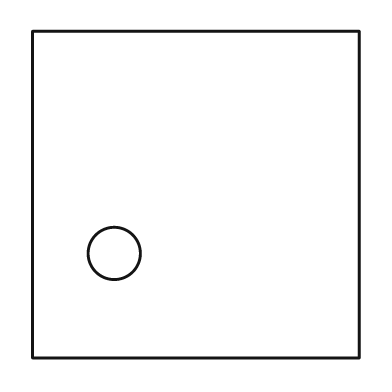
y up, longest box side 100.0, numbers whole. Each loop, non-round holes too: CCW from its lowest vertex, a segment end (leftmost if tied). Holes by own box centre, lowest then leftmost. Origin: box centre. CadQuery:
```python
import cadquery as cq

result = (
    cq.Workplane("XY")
    .moveTo(-50.0, -50.0)
    .lineTo(50.0, -50.0)
    .lineTo(50.0, 50.0)
    .lineTo(-50.0, 50.0)
    .close()
    .moveTo(-25.0, -18.0)
    .circle(8.0)
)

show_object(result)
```